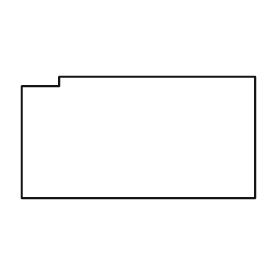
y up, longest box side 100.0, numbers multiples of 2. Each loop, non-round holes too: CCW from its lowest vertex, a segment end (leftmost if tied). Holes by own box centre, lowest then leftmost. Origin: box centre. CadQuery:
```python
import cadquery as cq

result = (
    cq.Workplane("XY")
    .moveTo(-50.0, -26.0)
    .lineTo(50.0, -26.0)
    .lineTo(50.0, 26.0)
    .lineTo(-34.0, 26.0)
    .lineTo(-34.0, 22.0)
    .lineTo(-50.0, 22.0)
    .close()
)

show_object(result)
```